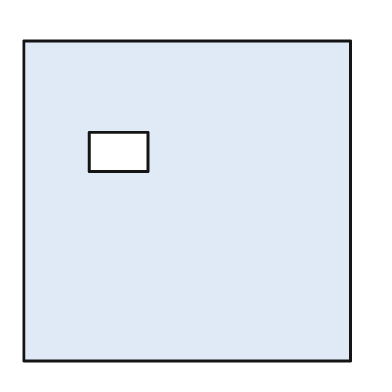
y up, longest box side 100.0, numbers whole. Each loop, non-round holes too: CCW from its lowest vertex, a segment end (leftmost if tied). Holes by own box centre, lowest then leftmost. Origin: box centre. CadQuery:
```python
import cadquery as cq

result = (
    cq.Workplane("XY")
    .moveTo(-50.0, -49.0)
    .lineTo(50.0, -49.0)
    .lineTo(50.0, 49.0)
    .lineTo(-50.0, 49.0)
    .close()
    .moveTo(-30.0, 9.0)
    .lineTo(-12.0, 9.0)
    .lineTo(-12.0, 21.0)
    .lineTo(-30.0, 21.0)
    .close()
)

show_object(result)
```